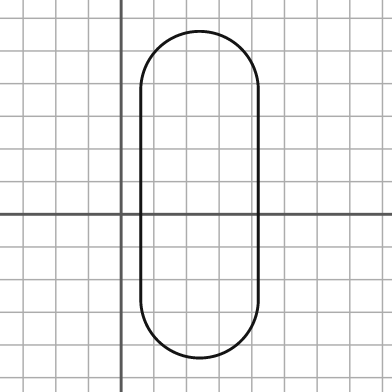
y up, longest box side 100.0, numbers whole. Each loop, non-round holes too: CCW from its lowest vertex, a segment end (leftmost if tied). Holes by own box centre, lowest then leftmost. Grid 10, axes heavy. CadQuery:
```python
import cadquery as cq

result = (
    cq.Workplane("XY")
    .moveTo(6.0, -26.0)
    .threePointArc((24.0, -44.0), (42.0, -26.0))
    .lineTo(42.0, 38.0)
    .threePointArc((24.0, 56.0), (6.0, 38.0))
    .close()
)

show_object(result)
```